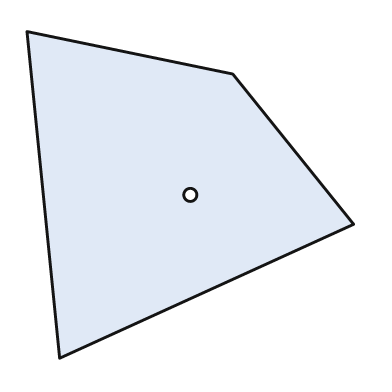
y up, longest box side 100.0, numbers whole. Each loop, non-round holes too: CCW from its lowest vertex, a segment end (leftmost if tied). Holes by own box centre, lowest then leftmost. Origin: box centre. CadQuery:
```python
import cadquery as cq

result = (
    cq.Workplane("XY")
    .moveTo(-40.0, -50.0)
    .lineTo(50.0, -9.0)
    .lineTo(13.0, 37.0)
    .lineTo(-50.0, 50.0)
    .close()
    .moveTo(0.0, 0.0)
    .circle(2.0)
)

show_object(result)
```